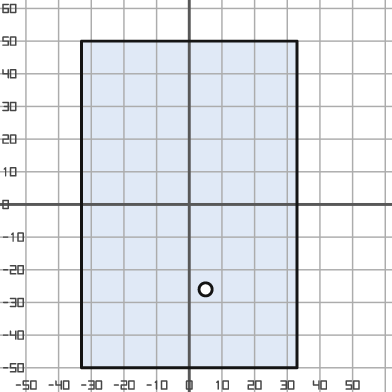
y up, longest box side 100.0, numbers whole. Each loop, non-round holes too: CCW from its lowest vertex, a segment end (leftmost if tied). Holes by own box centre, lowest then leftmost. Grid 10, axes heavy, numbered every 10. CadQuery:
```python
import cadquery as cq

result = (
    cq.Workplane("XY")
    .moveTo(-33.0, -50.0)
    .lineTo(33.0, -50.0)
    .lineTo(33.0, 50.0)
    .lineTo(-33.0, 50.0)
    .close()
    .moveTo(5.0, -26.0)
    .circle(2.0)
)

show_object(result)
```